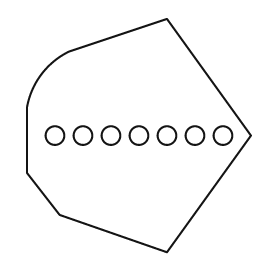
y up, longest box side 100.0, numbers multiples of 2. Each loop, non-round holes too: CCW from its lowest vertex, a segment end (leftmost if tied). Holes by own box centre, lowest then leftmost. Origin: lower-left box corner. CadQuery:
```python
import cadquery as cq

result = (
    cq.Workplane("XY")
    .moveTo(60.0, 0.0)
    .lineTo(96.0, 50.0)
    .lineTo(60.0, 100.0)
    .lineTo(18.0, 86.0)
    .threePointArc((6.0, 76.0), (0.0, 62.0))
    .lineTo(0.0, 34.0)
    .lineTo(14.0, 16.0)
    .close()
    .moveTo(12.0, 50.0)
    .circle(4.0)
    .moveTo(24.0, 50.0)
    .circle(4.0)
    .moveTo(36.0, 50.0)
    .circle(4.0)
    .moveTo(48.0, 50.0)
    .circle(4.0)
    .moveTo(60.0, 50.0)
    .circle(4.0)
    .moveTo(72.0, 50.0)
    .circle(4.0)
    .moveTo(84.0, 50.0)
    .circle(4.0)
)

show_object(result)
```